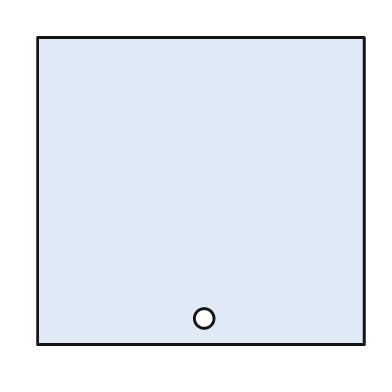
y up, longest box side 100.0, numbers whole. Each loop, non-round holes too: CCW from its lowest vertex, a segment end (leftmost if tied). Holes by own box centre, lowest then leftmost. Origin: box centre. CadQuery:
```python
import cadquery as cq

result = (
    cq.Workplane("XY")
    .moveTo(-50.0, -47.0)
    .lineTo(50.0, -47.0)
    .lineTo(50.0, 47.0)
    .lineTo(-50.0, 47.0)
    .close()
    .moveTo(1.0, -39.0)
    .circle(3.0)
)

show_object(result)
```